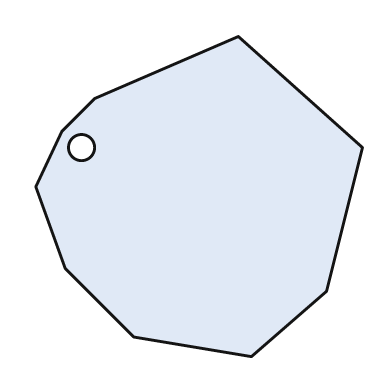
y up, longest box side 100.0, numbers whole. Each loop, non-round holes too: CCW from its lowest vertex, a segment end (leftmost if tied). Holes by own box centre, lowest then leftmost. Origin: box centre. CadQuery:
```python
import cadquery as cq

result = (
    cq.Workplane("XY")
    .moveTo(16.0, -49.0)
    .lineTo(39.0, -29.0)
    .lineTo(50.0, 15.0)
    .lineTo(12.0, 49.0)
    .lineTo(-32.0, 30.0)
    .lineTo(-42.0, 20.0)
    .lineTo(-50.0, 3.0)
    .lineTo(-41.0, -22.0)
    .lineTo(-20.0, -43.0)
    .close()
    .moveTo(-36.0, 15.0)
    .circle(4.0)
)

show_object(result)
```